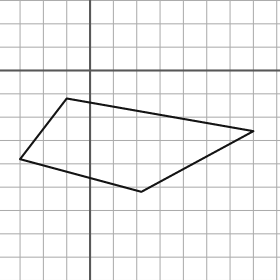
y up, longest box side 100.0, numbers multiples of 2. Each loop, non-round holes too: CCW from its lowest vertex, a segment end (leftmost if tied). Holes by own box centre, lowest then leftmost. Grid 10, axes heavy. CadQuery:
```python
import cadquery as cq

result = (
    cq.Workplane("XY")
    .moveTo(22.0, -52.0)
    .lineTo(70.0, -26.0)
    .lineTo(-10.0, -12.0)
    .lineTo(-30.0, -38.0)
    .close()
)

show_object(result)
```